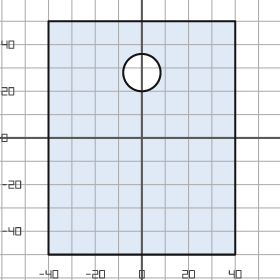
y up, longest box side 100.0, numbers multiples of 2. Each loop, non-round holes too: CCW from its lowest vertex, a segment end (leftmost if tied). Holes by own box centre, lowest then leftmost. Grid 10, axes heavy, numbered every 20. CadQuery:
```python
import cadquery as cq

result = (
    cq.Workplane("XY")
    .moveTo(-40.0, -50.0)
    .lineTo(40.0, -50.0)
    .lineTo(40.0, 50.0)
    .lineTo(-40.0, 50.0)
    .close()
    .moveTo(0.0, 28.0)
    .circle(8.0)
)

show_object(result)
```